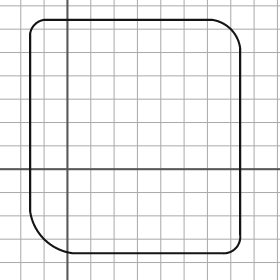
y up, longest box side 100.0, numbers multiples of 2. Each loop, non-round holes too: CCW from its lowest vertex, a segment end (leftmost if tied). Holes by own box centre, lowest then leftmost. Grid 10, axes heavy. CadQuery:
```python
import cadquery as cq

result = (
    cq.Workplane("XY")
    .moveTo(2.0, -36.0)
    .lineTo(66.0, -36.0)
    .threePointArc((72.0, -34.0), (74.0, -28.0))
    .lineTo(74.0, 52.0)
    .threePointArc((70.0, 60.0), (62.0, 64.0))
    .lineTo(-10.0, 64.0)
    .threePointArc((-14.0, 62.0), (-16.0, 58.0))
    .lineTo(-16.0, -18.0)
    .threePointArc((-10.0, -30.0), (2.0, -36.0))
    .close()
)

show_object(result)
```